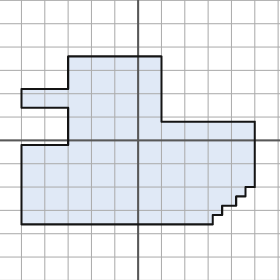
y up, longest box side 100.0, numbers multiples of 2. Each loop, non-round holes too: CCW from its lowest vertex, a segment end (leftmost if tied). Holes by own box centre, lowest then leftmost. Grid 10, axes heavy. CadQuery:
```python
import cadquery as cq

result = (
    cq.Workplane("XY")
    .moveTo(-50.0, -36.0)
    .lineTo(32.0, -36.0)
    .lineTo(32.0, -32.0)
    .lineTo(36.0, -32.0)
    .lineTo(36.0, -28.0)
    .lineTo(42.0, -28.0)
    .lineTo(42.0, -24.0)
    .lineTo(46.0, -24.0)
    .lineTo(46.0, -20.0)
    .lineTo(50.0, -20.0)
    .lineTo(50.0, 8.0)
    .lineTo(10.0, 8.0)
    .lineTo(10.0, 36.0)
    .lineTo(-30.0, 36.0)
    .lineTo(-30.0, 22.0)
    .lineTo(-50.0, 22.0)
    .lineTo(-50.0, 14.0)
    .lineTo(-30.0, 14.0)
    .lineTo(-30.0, -2.0)
    .lineTo(-50.0, -2.0)
    .close()
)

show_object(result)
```